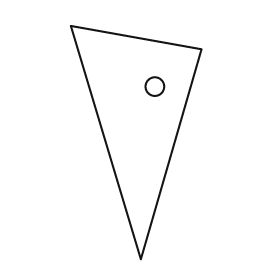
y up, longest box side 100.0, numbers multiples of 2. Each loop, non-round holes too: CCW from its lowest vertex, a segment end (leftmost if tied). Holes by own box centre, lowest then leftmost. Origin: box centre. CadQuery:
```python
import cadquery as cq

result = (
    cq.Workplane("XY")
    .moveTo(2.0, -50.0)
    .lineTo(28.0, 40.0)
    .lineTo(-28.0, 50.0)
    .close()
    .moveTo(8.0, 24.0)
    .circle(4.0)
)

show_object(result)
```